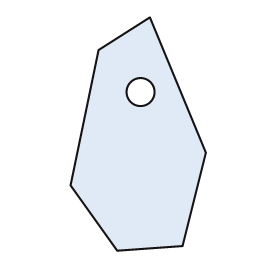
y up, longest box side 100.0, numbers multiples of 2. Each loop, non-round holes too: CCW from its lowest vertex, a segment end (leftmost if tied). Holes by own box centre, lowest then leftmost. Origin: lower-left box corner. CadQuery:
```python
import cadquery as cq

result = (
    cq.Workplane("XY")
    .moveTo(20.0, 0.0)
    .lineTo(48.0, 2.0)
    .lineTo(58.0, 42.0)
    .lineTo(34.0, 100.0)
    .lineTo(12.0, 86.0)
    .lineTo(0.0, 28.0)
    .close()
    .moveTo(30.0, 68.0)
    .circle(6.0)
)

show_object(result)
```